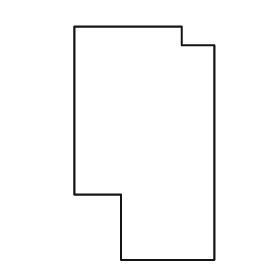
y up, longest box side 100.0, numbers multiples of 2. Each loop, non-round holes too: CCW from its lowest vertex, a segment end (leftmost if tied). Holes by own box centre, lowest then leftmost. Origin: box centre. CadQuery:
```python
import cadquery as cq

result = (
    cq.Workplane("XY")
    .moveTo(-10.0, -50.0)
    .lineTo(30.0, -50.0)
    .lineTo(30.0, 42.0)
    .lineTo(16.0, 42.0)
    .lineTo(16.0, 50.0)
    .lineTo(-30.0, 50.0)
    .lineTo(-30.0, -22.0)
    .lineTo(-10.0, -22.0)
    .close()
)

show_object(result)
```